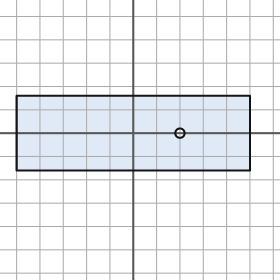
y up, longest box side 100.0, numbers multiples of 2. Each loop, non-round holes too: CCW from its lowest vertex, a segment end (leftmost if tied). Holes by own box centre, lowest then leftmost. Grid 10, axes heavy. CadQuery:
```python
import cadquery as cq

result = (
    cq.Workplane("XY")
    .moveTo(-50.0, -16.0)
    .lineTo(50.0, -16.0)
    .lineTo(50.0, 16.0)
    .lineTo(-50.0, 16.0)
    .close()
    .moveTo(20.0, 0.0)
    .circle(2.0)
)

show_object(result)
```